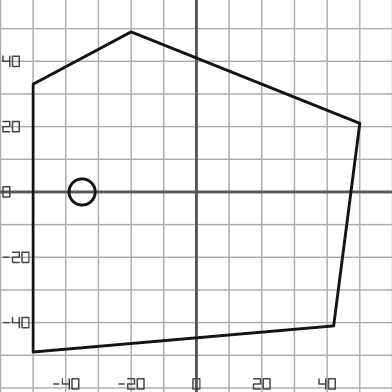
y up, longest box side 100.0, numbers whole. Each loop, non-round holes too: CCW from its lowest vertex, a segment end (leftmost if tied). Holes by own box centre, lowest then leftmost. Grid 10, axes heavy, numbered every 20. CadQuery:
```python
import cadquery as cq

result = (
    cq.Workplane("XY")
    .moveTo(-50.0, -49.0)
    .lineTo(42.0, -41.0)
    .lineTo(50.0, 21.0)
    .lineTo(-20.0, 49.0)
    .lineTo(-50.0, 33.0)
    .close()
    .moveTo(-35.0, 0.0)
    .circle(4.0)
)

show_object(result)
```